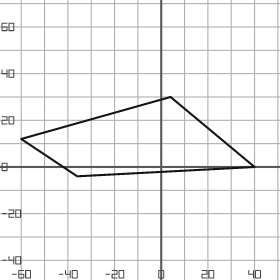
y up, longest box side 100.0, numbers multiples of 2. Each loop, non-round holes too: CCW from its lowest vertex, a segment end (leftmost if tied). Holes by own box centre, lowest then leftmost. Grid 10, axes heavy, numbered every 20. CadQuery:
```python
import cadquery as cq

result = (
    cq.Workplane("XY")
    .moveTo(-36.0, -4.0)
    .lineTo(40.0, 0.0)
    .lineTo(4.0, 30.0)
    .lineTo(-60.0, 12.0)
    .close()
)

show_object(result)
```